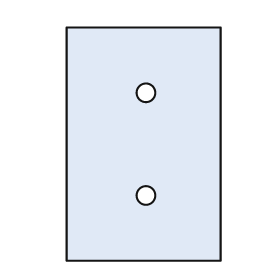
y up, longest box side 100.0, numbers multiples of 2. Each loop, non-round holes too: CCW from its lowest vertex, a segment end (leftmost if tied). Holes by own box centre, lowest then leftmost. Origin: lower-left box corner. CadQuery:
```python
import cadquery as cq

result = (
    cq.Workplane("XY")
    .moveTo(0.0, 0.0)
    .lineTo(66.0, 0.0)
    .lineTo(66.0, 100.0)
    .lineTo(0.0, 100.0)
    .close()
    .moveTo(34.0, 28.0)
    .circle(4.0)
    .moveTo(34.0, 72.0)
    .circle(4.0)
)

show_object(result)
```